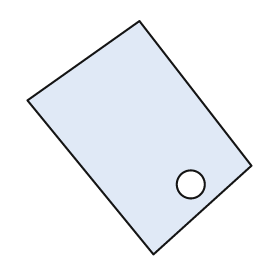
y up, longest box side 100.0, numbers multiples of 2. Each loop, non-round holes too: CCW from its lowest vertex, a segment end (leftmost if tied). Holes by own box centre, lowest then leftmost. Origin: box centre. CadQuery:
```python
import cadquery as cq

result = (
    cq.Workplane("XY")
    .moveTo(6.0, -50.0)
    .lineTo(48.0, -12.0)
    .lineTo(0.0, 50.0)
    .lineTo(-48.0, 16.0)
    .close()
    .moveTo(22.0, -20.0)
    .circle(6.0)
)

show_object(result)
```